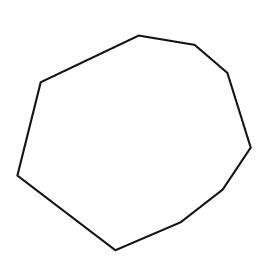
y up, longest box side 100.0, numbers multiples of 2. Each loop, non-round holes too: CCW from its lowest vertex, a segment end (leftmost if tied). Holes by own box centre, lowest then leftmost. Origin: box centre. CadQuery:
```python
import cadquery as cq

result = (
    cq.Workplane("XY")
    .moveTo(-8.0, -46.0)
    .lineTo(20.0, -34.0)
    .lineTo(38.0, -20.0)
    .lineTo(50.0, -2.0)
    .lineTo(40.0, 30.0)
    .lineTo(26.0, 42.0)
    .lineTo(2.0, 46.0)
    .lineTo(-40.0, 26.0)
    .lineTo(-50.0, -14.0)
    .close()
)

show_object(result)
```